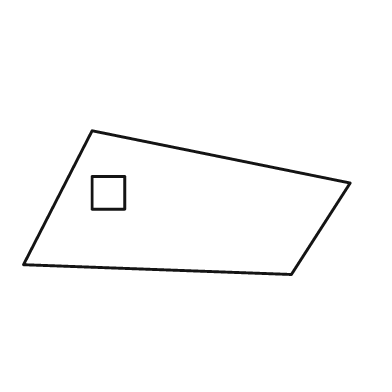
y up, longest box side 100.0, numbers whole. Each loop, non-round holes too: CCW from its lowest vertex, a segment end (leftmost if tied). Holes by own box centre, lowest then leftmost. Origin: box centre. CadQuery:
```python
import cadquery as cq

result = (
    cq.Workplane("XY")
    .moveTo(32.0, -22.0)
    .lineTo(50.0, 6.0)
    .lineTo(-29.0, 22.0)
    .lineTo(-50.0, -19.0)
    .close()
    .moveTo(-29.0, -2.0)
    .lineTo(-19.0, -2.0)
    .lineTo(-19.0, 8.0)
    .lineTo(-29.0, 8.0)
    .close()
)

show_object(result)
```